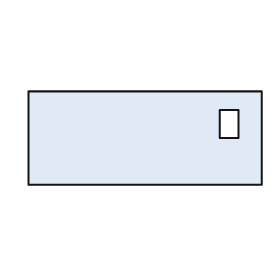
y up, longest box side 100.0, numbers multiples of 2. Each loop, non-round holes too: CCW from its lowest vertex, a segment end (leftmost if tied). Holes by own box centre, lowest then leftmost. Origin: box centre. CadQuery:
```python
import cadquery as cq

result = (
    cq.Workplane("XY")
    .moveTo(-50.0, -20.0)
    .lineTo(50.0, -20.0)
    .lineTo(50.0, 20.0)
    .lineTo(-50.0, 20.0)
    .close()
    .moveTo(32.0, 0.0)
    .lineTo(40.0, 0.0)
    .lineTo(40.0, 12.0)
    .lineTo(32.0, 12.0)
    .close()
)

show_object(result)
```